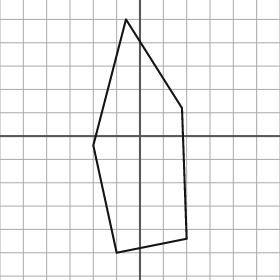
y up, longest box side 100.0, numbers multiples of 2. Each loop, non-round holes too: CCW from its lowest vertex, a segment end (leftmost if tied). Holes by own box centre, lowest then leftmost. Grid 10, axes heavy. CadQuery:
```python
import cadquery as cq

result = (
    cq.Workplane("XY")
    .moveTo(-10.0, -50.0)
    .lineTo(20.0, -44.0)
    .lineTo(18.0, 12.0)
    .lineTo(-6.0, 50.0)
    .lineTo(-20.0, -4.0)
    .close()
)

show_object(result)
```